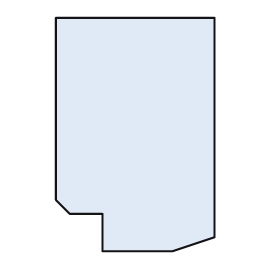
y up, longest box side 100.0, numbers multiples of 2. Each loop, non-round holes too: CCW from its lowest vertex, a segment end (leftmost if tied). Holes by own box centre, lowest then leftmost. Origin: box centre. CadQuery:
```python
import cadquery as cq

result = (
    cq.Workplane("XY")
    .moveTo(-14.0, -50.0)
    .lineTo(16.0, -50.0)
    .lineTo(34.0, -44.0)
    .lineTo(34.0, 50.0)
    .lineTo(-34.0, 50.0)
    .lineTo(-34.0, -28.0)
    .lineTo(-28.0, -34.0)
    .lineTo(-14.0, -34.0)
    .close()
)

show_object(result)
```